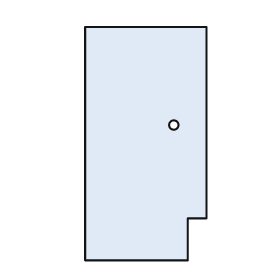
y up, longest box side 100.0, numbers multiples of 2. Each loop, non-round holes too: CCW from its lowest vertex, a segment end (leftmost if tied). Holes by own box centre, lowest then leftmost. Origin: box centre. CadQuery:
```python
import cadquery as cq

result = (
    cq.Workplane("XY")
    .moveTo(-26.0, -50.0)
    .lineTo(18.0, -50.0)
    .lineTo(18.0, -32.0)
    .lineTo(26.0, -32.0)
    .lineTo(26.0, 50.0)
    .lineTo(-26.0, 50.0)
    .close()
    .moveTo(12.0, 8.0)
    .circle(2.0)
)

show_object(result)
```